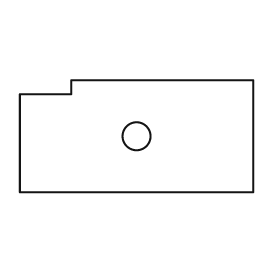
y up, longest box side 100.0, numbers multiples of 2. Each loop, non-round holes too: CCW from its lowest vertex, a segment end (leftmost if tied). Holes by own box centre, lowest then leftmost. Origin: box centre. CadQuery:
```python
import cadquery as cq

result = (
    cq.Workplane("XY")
    .moveTo(-50.0, -24.0)
    .lineTo(50.0, -24.0)
    .lineTo(50.0, 24.0)
    .lineTo(-28.0, 24.0)
    .lineTo(-28.0, 18.0)
    .lineTo(-50.0, 18.0)
    .close()
    .moveTo(0.0, 0.0)
    .circle(6.0)
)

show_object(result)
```